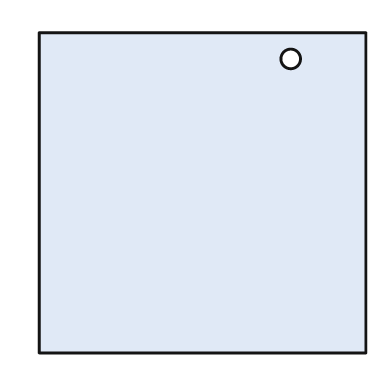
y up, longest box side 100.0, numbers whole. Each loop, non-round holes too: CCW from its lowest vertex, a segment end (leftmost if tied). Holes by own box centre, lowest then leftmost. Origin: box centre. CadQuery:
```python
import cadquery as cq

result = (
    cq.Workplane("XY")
    .moveTo(-50.0, -49.0)
    .lineTo(50.0, -49.0)
    .lineTo(50.0, 49.0)
    .lineTo(-50.0, 49.0)
    .close()
    .moveTo(27.0, 41.0)
    .circle(3.0)
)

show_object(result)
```